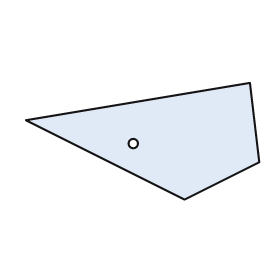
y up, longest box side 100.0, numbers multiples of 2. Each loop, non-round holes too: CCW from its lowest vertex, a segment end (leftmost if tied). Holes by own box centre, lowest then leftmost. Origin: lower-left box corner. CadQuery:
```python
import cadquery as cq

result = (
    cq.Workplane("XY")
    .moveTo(68.0, 0.0)
    .lineTo(100.0, 16.0)
    .lineTo(96.0, 50.0)
    .lineTo(0.0, 34.0)
    .close()
    .moveTo(46.0, 24.0)
    .circle(2.0)
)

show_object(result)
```